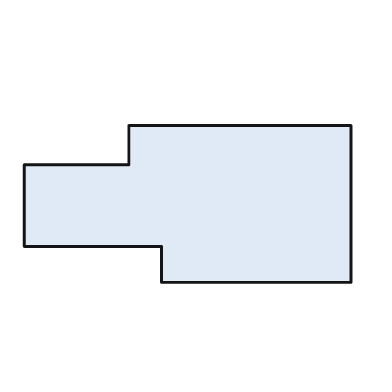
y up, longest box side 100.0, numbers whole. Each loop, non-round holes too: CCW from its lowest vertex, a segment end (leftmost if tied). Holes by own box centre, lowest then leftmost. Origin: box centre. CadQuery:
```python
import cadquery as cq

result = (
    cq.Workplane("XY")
    .moveTo(-8.0, -24.0)
    .lineTo(50.0, -24.0)
    .lineTo(50.0, 24.0)
    .lineTo(-18.0, 24.0)
    .lineTo(-18.0, 12.0)
    .lineTo(-50.0, 12.0)
    .lineTo(-50.0, -13.0)
    .lineTo(-8.0, -13.0)
    .close()
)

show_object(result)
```